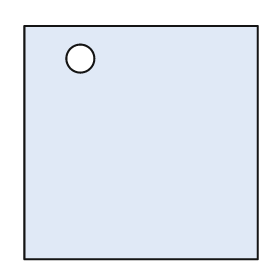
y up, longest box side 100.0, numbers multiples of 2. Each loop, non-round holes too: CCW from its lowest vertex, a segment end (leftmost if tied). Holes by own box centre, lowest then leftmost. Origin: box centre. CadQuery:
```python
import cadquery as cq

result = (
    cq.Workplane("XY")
    .moveTo(-50.0, -50.0)
    .lineTo(50.0, -50.0)
    .lineTo(50.0, 50.0)
    .lineTo(-50.0, 50.0)
    .close()
    .moveTo(-26.0, 36.0)
    .circle(6.0)
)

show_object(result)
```